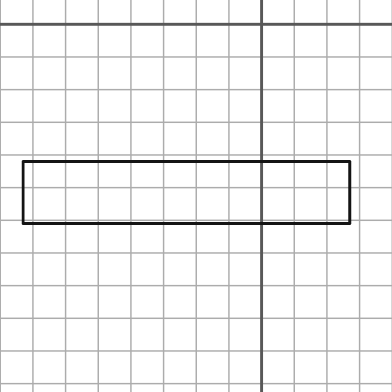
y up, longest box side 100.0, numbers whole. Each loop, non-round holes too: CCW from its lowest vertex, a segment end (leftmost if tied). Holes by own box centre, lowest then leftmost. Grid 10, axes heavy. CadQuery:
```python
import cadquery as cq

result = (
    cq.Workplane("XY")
    .moveTo(-73.0, -61.0)
    .lineTo(27.0, -61.0)
    .lineTo(27.0, -42.0)
    .lineTo(-73.0, -42.0)
    .close()
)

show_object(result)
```